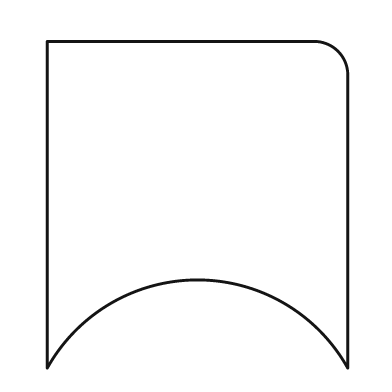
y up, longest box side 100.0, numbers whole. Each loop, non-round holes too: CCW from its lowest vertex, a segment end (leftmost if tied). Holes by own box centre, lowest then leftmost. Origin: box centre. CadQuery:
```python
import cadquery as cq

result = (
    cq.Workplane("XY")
    .moveTo(-46.0, -50.0)
    .threePointArc((0.0, -23.0), (46.0, -50.0))
    .lineTo(46.0, 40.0)
    .threePointArc((43.0, 47.0), (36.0, 50.0))
    .lineTo(-46.0, 50.0)
    .close()
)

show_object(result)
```